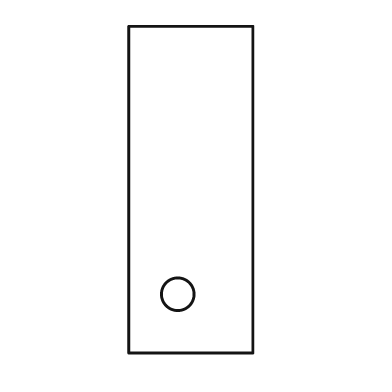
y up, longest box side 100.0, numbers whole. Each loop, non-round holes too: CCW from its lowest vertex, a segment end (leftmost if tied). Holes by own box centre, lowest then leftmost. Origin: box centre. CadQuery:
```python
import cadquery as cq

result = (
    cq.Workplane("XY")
    .moveTo(-19.0, -50.0)
    .lineTo(19.0, -50.0)
    .lineTo(19.0, 50.0)
    .lineTo(-19.0, 50.0)
    .close()
    .moveTo(-4.0, -32.0)
    .circle(5.0)
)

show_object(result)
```